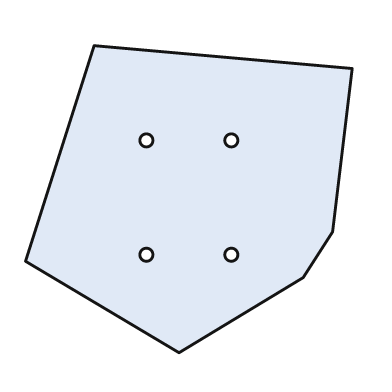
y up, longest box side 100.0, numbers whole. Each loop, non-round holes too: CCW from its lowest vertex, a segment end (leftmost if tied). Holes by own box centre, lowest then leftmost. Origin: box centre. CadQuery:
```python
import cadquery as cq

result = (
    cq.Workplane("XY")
    .moveTo(-3.0, -47.0)
    .lineTo(35.0, -24.0)
    .lineTo(44.0, -10.0)
    .lineTo(50.0, 40.0)
    .lineTo(-29.0, 47.0)
    .lineTo(-50.0, -19.0)
    .close()
    .moveTo(-13.0, -17.0)
    .circle(2.0)
    .moveTo(13.0, -17.0)
    .circle(2.0)
    .moveTo(-13.0, 18.0)
    .circle(2.0)
    .moveTo(13.0, 18.0)
    .circle(2.0)
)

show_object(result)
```